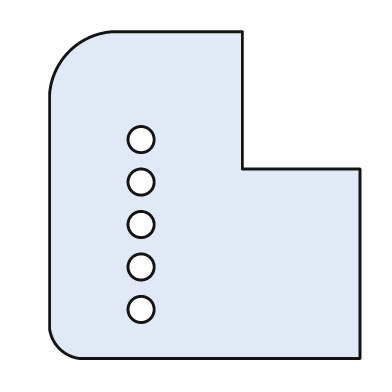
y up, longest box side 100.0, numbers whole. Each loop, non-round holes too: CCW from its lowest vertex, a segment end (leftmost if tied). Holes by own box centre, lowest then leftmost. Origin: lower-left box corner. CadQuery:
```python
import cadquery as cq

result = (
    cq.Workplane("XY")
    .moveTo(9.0, 0.0)
    .lineTo(95.0, 0.0)
    .lineTo(95.0, 58.0)
    .lineTo(59.0, 58.0)
    .lineTo(59.0, 100.0)
    .lineTo(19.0, 100.0)
    .threePointArc((6.0, 94.0), (0.0, 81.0))
    .lineTo(0.0, 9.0)
    .threePointArc((3.0, 3.0), (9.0, 0.0))
    .close()
    .moveTo(28.0, 15.0)
    .circle(4.0)
    .moveTo(28.0, 28.0)
    .circle(4.0)
    .moveTo(28.0, 41.0)
    .circle(4.0)
    .moveTo(28.0, 54.0)
    .circle(4.0)
    .moveTo(28.0, 67.0)
    .circle(4.0)
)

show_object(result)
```